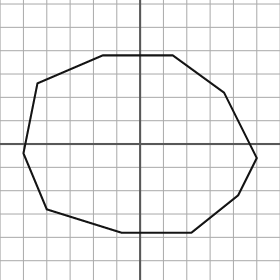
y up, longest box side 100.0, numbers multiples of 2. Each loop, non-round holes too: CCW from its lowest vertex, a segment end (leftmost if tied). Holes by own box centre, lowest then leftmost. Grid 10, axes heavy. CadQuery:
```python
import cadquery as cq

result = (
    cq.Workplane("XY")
    .moveTo(-8.0, -38.0)
    .lineTo(22.0, -38.0)
    .lineTo(42.0, -22.0)
    .lineTo(50.0, -6.0)
    .lineTo(36.0, 22.0)
    .lineTo(14.0, 38.0)
    .lineTo(-16.0, 38.0)
    .lineTo(-44.0, 26.0)
    .lineTo(-50.0, -4.0)
    .lineTo(-40.0, -28.0)
    .close()
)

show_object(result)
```